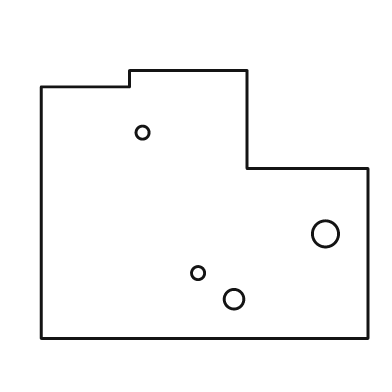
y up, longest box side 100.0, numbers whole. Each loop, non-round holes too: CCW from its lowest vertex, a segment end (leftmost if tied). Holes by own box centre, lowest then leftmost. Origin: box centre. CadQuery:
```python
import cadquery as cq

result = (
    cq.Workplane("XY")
    .moveTo(-50.0, -41.0)
    .lineTo(50.0, -41.0)
    .lineTo(50.0, 11.0)
    .lineTo(13.0, 11.0)
    .lineTo(13.0, 41.0)
    .lineTo(-23.0, 41.0)
    .lineTo(-23.0, 36.0)
    .lineTo(-50.0, 36.0)
    .close()
    .moveTo(9.0, -29.0)
    .circle(3.0)
    .moveTo(-2.0, -21.0)
    .circle(2.0)
    .moveTo(37.0, -9.0)
    .circle(4.0)
    .moveTo(-19.0, 22.0)
    .circle(2.0)
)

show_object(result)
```